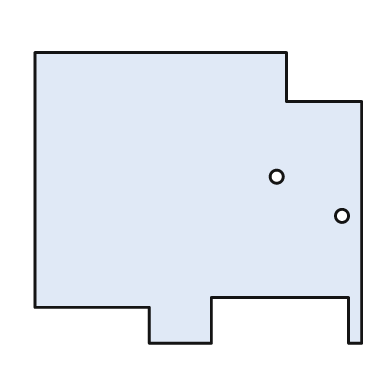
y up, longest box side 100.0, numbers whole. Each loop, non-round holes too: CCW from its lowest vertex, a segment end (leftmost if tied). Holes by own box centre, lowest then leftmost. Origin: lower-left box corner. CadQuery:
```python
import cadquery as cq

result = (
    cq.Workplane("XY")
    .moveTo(35.0, 0.0)
    .lineTo(54.0, 0.0)
    .lineTo(54.0, 14.0)
    .lineTo(96.0, 14.0)
    .lineTo(96.0, 0.0)
    .lineTo(100.0, 0.0)
    .lineTo(100.0, 74.0)
    .lineTo(77.0, 74.0)
    .lineTo(77.0, 89.0)
    .lineTo(0.0, 89.0)
    .lineTo(0.0, 11.0)
    .lineTo(35.0, 11.0)
    .close()
    .moveTo(94.0, 39.0)
    .circle(2.0)
    .moveTo(74.0, 51.0)
    .circle(2.0)
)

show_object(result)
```